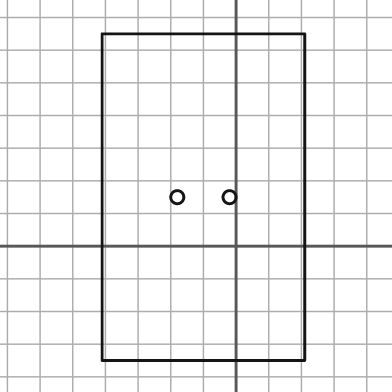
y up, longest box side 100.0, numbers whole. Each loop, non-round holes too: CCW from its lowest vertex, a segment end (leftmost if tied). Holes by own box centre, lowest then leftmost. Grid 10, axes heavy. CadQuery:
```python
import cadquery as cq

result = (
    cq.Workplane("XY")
    .moveTo(-41.0, -35.0)
    .lineTo(21.0, -35.0)
    .lineTo(21.0, 65.0)
    .lineTo(-41.0, 65.0)
    .close()
    .moveTo(-18.0, 15.0)
    .circle(2.0)
    .moveTo(-2.0, 15.0)
    .circle(2.0)
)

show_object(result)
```